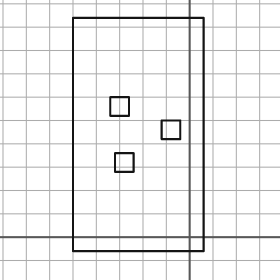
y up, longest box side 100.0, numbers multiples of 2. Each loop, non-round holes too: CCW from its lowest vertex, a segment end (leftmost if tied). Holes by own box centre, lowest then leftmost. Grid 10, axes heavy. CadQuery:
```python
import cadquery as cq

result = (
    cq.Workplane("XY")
    .moveTo(-50.0, -6.0)
    .lineTo(6.0, -6.0)
    .lineTo(6.0, 94.0)
    .lineTo(-50.0, 94.0)
    .close()
    .moveTo(-32.0, 28.0)
    .lineTo(-24.0, 28.0)
    .lineTo(-24.0, 36.0)
    .lineTo(-32.0, 36.0)
    .close()
    .moveTo(-12.0, 42.0)
    .lineTo(-4.0, 42.0)
    .lineTo(-4.0, 50.0)
    .lineTo(-12.0, 50.0)
    .close()
    .moveTo(-34.0, 52.0)
    .lineTo(-26.0, 52.0)
    .lineTo(-26.0, 60.0)
    .lineTo(-34.0, 60.0)
    .close()
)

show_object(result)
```